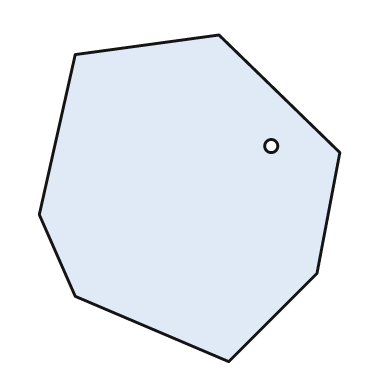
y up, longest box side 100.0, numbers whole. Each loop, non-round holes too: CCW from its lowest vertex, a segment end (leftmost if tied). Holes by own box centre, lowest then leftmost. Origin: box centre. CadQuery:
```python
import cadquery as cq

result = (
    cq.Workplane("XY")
    .moveTo(12.0, -50.0)
    .lineTo(39.0, -23.0)
    .lineTo(46.0, 14.0)
    .lineTo(9.0, 50.0)
    .lineTo(-35.0, 44.0)
    .lineTo(-46.0, -5.0)
    .lineTo(-35.0, -30.0)
    .close()
    .moveTo(25.0, 16.0)
    .circle(2.0)
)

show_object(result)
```